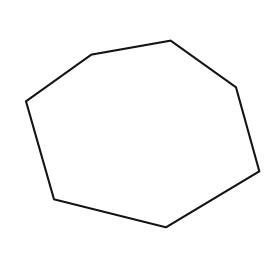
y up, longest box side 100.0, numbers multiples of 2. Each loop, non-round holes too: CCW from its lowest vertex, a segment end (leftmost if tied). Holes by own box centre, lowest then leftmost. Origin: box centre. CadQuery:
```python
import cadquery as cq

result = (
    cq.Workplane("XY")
    .moveTo(10.0, -40.0)
    .lineTo(50.0, -16.0)
    .lineTo(40.0, 20.0)
    .lineTo(12.0, 40.0)
    .lineTo(-22.0, 34.0)
    .lineTo(-50.0, 14.0)
    .lineTo(-38.0, -28.0)
    .close()
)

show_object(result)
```